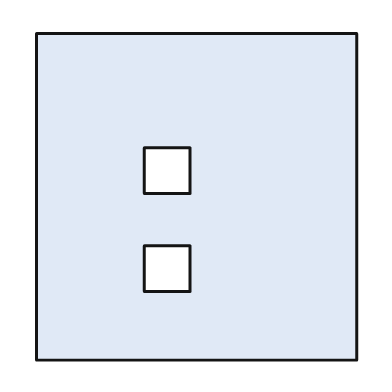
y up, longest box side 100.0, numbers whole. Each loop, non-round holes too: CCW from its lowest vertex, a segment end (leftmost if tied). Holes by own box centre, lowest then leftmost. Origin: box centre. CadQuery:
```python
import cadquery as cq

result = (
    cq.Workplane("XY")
    .moveTo(-49.0, -50.0)
    .lineTo(49.0, -50.0)
    .lineTo(49.0, 50.0)
    .lineTo(-49.0, 50.0)
    .close()
    .moveTo(-16.0, -29.0)
    .lineTo(-2.0, -29.0)
    .lineTo(-2.0, -15.0)
    .lineTo(-16.0, -15.0)
    .close()
    .moveTo(-16.0, 1.0)
    .lineTo(-2.0, 1.0)
    .lineTo(-2.0, 15.0)
    .lineTo(-16.0, 15.0)
    .close()
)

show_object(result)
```